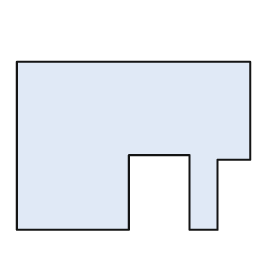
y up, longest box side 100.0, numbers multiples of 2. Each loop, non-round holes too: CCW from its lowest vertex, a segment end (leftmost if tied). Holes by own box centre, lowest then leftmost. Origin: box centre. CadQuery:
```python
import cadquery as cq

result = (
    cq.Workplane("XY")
    .moveTo(-50.0, -36.0)
    .lineTo(-2.0, -36.0)
    .lineTo(-2.0, -4.0)
    .lineTo(24.0, -4.0)
    .lineTo(24.0, -36.0)
    .lineTo(36.0, -36.0)
    .lineTo(36.0, -6.0)
    .lineTo(50.0, -6.0)
    .lineTo(50.0, 36.0)
    .lineTo(-50.0, 36.0)
    .close()
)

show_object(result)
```